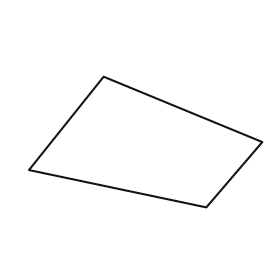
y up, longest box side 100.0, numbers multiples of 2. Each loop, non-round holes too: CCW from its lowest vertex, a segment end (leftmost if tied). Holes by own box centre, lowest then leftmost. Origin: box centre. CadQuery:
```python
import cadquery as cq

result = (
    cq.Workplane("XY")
    .moveTo(26.0, -28.0)
    .lineTo(50.0, 0.0)
    .lineTo(-18.0, 28.0)
    .lineTo(-50.0, -12.0)
    .close()
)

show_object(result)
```